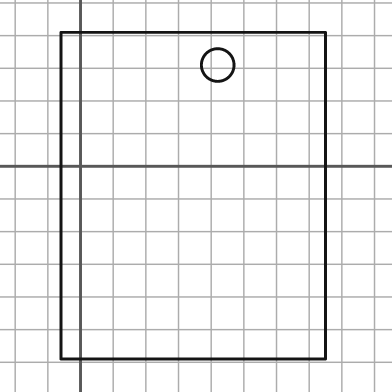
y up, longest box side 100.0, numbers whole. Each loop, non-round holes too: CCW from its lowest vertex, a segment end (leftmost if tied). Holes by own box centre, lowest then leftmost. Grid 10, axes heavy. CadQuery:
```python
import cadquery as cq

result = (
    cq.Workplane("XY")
    .moveTo(-6.0, -59.0)
    .lineTo(75.0, -59.0)
    .lineTo(75.0, 41.0)
    .lineTo(-6.0, 41.0)
    .close()
    .moveTo(42.0, 31.0)
    .circle(5.0)
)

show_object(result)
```